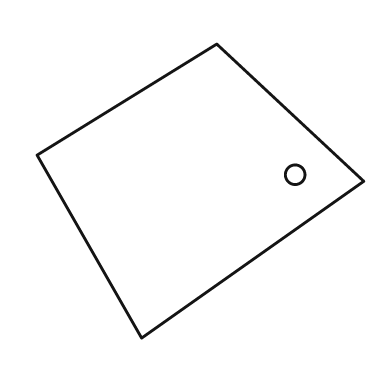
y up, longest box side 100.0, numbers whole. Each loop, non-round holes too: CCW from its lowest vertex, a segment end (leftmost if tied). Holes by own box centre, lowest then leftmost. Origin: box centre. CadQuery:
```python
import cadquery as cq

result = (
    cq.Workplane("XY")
    .moveTo(-18.0, -45.0)
    .lineTo(50.0, 3.0)
    .lineTo(5.0, 45.0)
    .lineTo(-50.0, 11.0)
    .close()
    .moveTo(29.0, 5.0)
    .circle(3.0)
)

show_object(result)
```